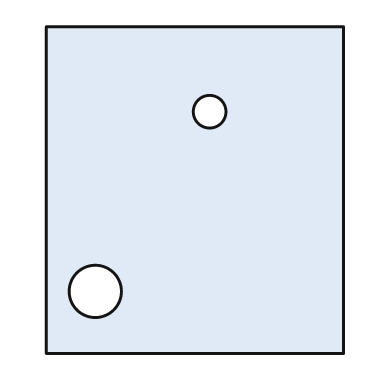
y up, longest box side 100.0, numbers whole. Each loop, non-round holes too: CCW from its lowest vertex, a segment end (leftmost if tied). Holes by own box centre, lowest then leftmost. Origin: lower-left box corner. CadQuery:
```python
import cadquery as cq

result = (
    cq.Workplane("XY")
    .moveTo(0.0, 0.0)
    .lineTo(91.0, 0.0)
    .lineTo(91.0, 100.0)
    .lineTo(0.0, 100.0)
    .close()
    .moveTo(15.0, 19.0)
    .circle(8.0)
    .moveTo(50.0, 74.0)
    .circle(5.0)
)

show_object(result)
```